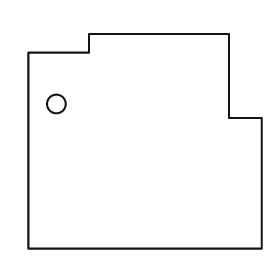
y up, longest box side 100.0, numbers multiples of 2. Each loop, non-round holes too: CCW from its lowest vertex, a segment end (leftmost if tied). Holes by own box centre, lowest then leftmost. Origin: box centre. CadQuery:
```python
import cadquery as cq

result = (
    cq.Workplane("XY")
    .moveTo(-50.0, -46.0)
    .lineTo(50.0, -46.0)
    .lineTo(50.0, 10.0)
    .lineTo(36.0, 10.0)
    .lineTo(36.0, 46.0)
    .lineTo(-24.0, 46.0)
    .lineTo(-24.0, 38.0)
    .lineTo(-50.0, 38.0)
    .close()
    .moveTo(-38.0, 16.0)
    .circle(4.0)
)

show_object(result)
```